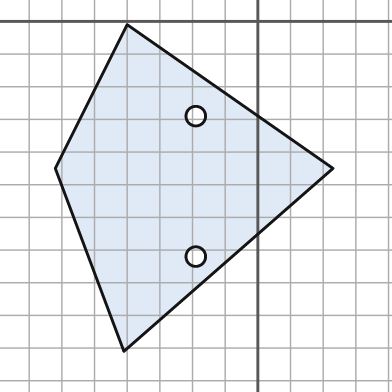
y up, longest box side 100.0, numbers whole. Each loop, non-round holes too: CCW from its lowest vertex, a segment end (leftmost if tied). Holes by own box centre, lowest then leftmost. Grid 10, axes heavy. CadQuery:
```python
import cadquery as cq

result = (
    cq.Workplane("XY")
    .moveTo(-41.0, -101.0)
    .lineTo(23.0, -45.0)
    .lineTo(-40.0, -1.0)
    .lineTo(-62.0, -45.0)
    .close()
    .moveTo(-19.0, -72.0)
    .circle(3.0)
    .moveTo(-19.0, -29.0)
    .circle(3.0)
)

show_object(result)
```